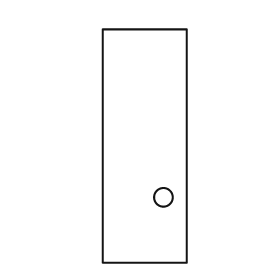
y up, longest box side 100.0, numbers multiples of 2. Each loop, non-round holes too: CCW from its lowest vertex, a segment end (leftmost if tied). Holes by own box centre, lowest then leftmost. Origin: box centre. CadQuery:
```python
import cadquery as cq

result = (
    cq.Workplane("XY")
    .moveTo(-18.0, -50.0)
    .lineTo(18.0, -50.0)
    .lineTo(18.0, 50.0)
    .lineTo(-18.0, 50.0)
    .close()
    .moveTo(8.0, -22.0)
    .circle(4.0)
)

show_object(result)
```